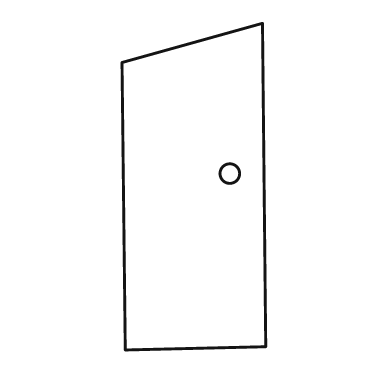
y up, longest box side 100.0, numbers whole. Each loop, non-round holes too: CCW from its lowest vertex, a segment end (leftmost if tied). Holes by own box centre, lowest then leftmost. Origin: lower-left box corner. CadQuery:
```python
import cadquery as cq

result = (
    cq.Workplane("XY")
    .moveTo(1.0, 0.0)
    .lineTo(44.0, 1.0)
    .lineTo(43.0, 100.0)
    .lineTo(0.0, 88.0)
    .close()
    .moveTo(33.0, 54.0)
    .circle(3.0)
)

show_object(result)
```